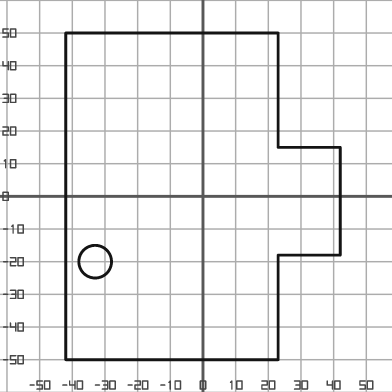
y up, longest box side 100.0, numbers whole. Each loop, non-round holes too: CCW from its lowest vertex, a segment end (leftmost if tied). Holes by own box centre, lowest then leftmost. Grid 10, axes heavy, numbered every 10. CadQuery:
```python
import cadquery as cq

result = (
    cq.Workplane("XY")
    .moveTo(-42.0, -50.0)
    .lineTo(23.0, -50.0)
    .lineTo(23.0, -18.0)
    .lineTo(42.0, -18.0)
    .lineTo(42.0, 15.0)
    .lineTo(23.0, 15.0)
    .lineTo(23.0, 50.0)
    .lineTo(-42.0, 50.0)
    .close()
    .moveTo(-33.0, -20.0)
    .circle(5.0)
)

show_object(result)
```